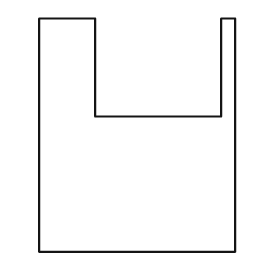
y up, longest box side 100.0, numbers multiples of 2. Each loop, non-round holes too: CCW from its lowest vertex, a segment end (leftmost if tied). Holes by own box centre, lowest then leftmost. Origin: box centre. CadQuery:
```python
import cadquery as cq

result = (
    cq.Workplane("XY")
    .moveTo(-42.0, -50.0)
    .lineTo(42.0, -50.0)
    .lineTo(42.0, 50.0)
    .lineTo(36.0, 50.0)
    .lineTo(36.0, 8.0)
    .lineTo(-18.0, 8.0)
    .lineTo(-18.0, 50.0)
    .lineTo(-42.0, 50.0)
    .close()
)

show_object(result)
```